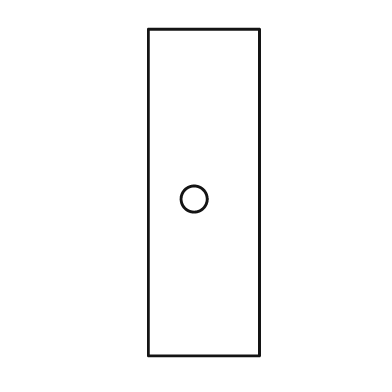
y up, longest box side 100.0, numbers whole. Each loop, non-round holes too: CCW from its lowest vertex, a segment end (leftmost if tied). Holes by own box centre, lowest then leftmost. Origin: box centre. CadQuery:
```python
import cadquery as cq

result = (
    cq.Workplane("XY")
    .moveTo(-17.0, -50.0)
    .lineTo(17.0, -50.0)
    .lineTo(17.0, 50.0)
    .lineTo(-17.0, 50.0)
    .close()
    .moveTo(-3.0, -2.0)
    .circle(4.0)
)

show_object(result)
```